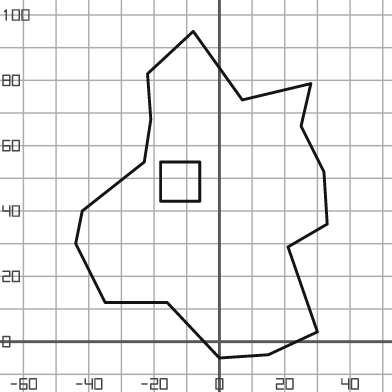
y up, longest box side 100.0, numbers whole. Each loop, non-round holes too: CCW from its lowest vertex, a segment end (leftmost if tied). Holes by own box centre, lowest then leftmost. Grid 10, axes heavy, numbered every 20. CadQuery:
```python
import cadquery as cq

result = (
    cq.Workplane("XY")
    .moveTo(0.0, -5.0)
    .lineTo(15.0, -4.0)
    .lineTo(30.0, 3.0)
    .lineTo(21.0, 29.0)
    .lineTo(33.0, 36.0)
    .lineTo(32.0, 52.0)
    .lineTo(25.0, 66.0)
    .lineTo(28.0, 79.0)
    .lineTo(7.0, 74.0)
    .lineTo(-8.0, 95.0)
    .lineTo(-22.0, 82.0)
    .lineTo(-21.0, 68.0)
    .lineTo(-23.0, 55.0)
    .lineTo(-42.0, 40.0)
    .lineTo(-44.0, 30.0)
    .lineTo(-35.0, 12.0)
    .lineTo(-16.0, 12.0)
    .close()
    .moveTo(-18.0, 43.0)
    .lineTo(-6.0, 43.0)
    .lineTo(-6.0, 55.0)
    .lineTo(-18.0, 55.0)
    .close()
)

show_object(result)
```